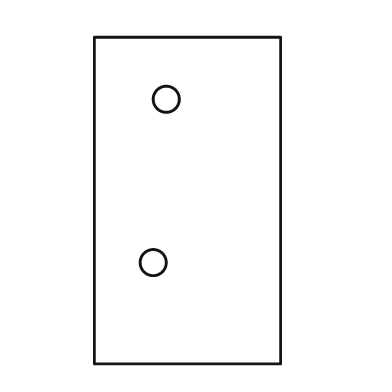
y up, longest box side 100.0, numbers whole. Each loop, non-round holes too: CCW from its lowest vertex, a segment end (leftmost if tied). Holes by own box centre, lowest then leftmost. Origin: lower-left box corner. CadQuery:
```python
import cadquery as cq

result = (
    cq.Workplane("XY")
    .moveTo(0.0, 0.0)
    .lineTo(57.0, 0.0)
    .lineTo(57.0, 100.0)
    .lineTo(0.0, 100.0)
    .close()
    .moveTo(18.0, 31.0)
    .circle(4.0)
    .moveTo(22.0, 81.0)
    .circle(4.0)
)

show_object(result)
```